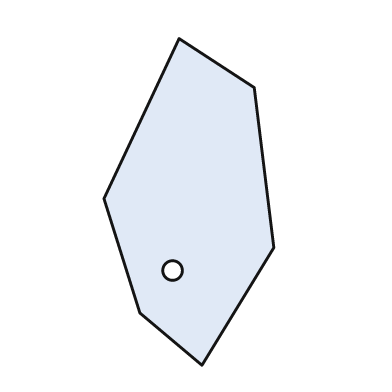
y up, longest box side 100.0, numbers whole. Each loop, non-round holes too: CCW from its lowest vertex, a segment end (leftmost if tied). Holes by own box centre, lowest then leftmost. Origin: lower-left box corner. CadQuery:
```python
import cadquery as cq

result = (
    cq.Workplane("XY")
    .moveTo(30.0, 0.0)
    .lineTo(52.0, 36.0)
    .lineTo(46.0, 85.0)
    .lineTo(23.0, 100.0)
    .lineTo(0.0, 51.0)
    .lineTo(11.0, 16.0)
    .close()
    .moveTo(21.0, 29.0)
    .circle(3.0)
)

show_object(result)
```